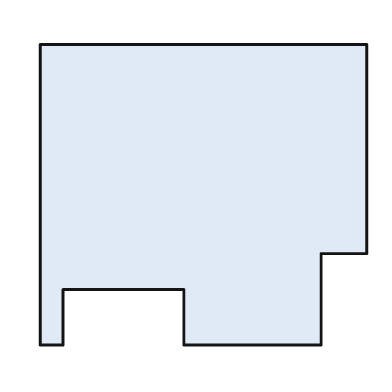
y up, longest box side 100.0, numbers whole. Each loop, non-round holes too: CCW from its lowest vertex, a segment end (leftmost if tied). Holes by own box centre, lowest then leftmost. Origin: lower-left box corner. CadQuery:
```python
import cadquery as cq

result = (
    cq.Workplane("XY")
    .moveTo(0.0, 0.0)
    .lineTo(7.0, 0.0)
    .lineTo(7.0, 17.0)
    .lineTo(44.0, 17.0)
    .lineTo(44.0, 0.0)
    .lineTo(86.0, 0.0)
    .lineTo(86.0, 28.0)
    .lineTo(100.0, 28.0)
    .lineTo(100.0, 92.0)
    .lineTo(0.0, 92.0)
    .close()
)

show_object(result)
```